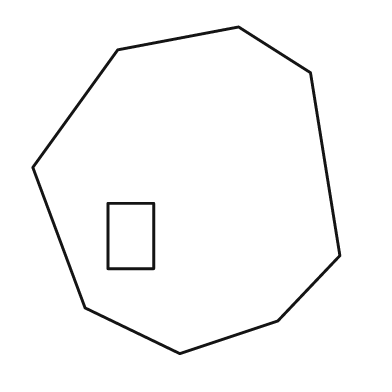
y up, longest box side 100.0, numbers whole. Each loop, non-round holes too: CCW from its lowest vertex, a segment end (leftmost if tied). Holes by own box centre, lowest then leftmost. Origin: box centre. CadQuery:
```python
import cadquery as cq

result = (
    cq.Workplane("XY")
    .moveTo(-2.0, -50.0)
    .lineTo(28.0, -40.0)
    .lineTo(47.0, -20.0)
    .lineTo(38.0, 36.0)
    .lineTo(16.0, 50.0)
    .lineTo(-21.0, 43.0)
    .lineTo(-47.0, 7.0)
    .lineTo(-31.0, -36.0)
    .close()
    .moveTo(-24.0, -24.0)
    .lineTo(-10.0, -24.0)
    .lineTo(-10.0, -4.0)
    .lineTo(-24.0, -4.0)
    .close()
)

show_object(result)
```